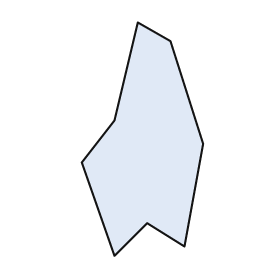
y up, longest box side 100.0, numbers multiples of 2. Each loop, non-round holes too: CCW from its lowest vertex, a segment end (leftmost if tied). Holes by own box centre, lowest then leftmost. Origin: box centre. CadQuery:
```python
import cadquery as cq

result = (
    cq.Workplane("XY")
    .moveTo(-12.0, -50.0)
    .lineTo(2.0, -36.0)
    .lineTo(18.0, -46.0)
    .lineTo(26.0, -2.0)
    .lineTo(12.0, 42.0)
    .lineTo(-2.0, 50.0)
    .lineTo(-12.0, 8.0)
    .lineTo(-26.0, -10.0)
    .close()
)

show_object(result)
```